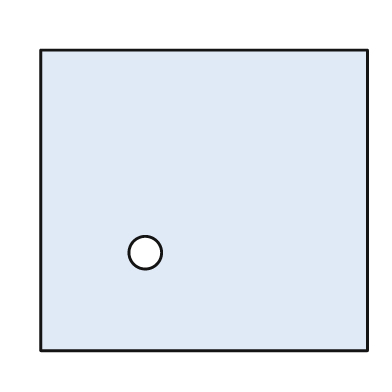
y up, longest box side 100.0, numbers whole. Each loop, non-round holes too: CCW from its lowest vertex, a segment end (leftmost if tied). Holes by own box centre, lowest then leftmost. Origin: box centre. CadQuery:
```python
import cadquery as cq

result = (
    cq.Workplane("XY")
    .moveTo(-50.0, -46.0)
    .lineTo(50.0, -46.0)
    .lineTo(50.0, 46.0)
    .lineTo(-50.0, 46.0)
    .close()
    .moveTo(-18.0, -16.0)
    .circle(5.0)
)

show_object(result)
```